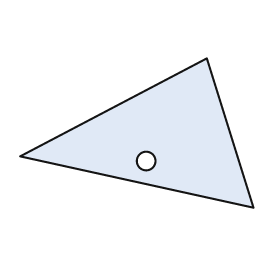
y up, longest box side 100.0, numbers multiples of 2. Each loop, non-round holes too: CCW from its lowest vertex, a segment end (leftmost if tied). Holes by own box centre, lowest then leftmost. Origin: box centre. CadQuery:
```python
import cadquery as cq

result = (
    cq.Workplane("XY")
    .moveTo(50.0, -32.0)
    .lineTo(30.0, 32.0)
    .lineTo(-50.0, -10.0)
    .close()
    .moveTo(4.0, -12.0)
    .circle(4.0)
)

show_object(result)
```